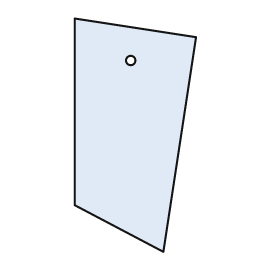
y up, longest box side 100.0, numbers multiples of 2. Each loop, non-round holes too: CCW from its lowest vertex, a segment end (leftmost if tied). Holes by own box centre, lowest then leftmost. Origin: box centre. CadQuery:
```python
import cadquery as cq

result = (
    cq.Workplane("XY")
    .moveTo(12.0, -50.0)
    .lineTo(26.0, 42.0)
    .lineTo(-26.0, 50.0)
    .lineTo(-26.0, -30.0)
    .close()
    .moveTo(-2.0, 32.0)
    .circle(2.0)
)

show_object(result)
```